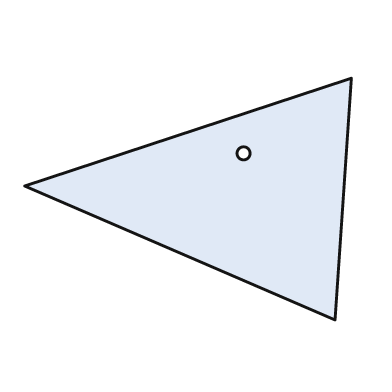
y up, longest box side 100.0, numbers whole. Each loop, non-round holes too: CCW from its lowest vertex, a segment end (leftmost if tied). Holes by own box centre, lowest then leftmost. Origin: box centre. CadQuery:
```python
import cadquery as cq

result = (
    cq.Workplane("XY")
    .moveTo(45.0, -37.0)
    .lineTo(50.0, 37.0)
    .lineTo(-50.0, 4.0)
    .close()
    .moveTo(17.0, 14.0)
    .circle(2.0)
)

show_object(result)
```